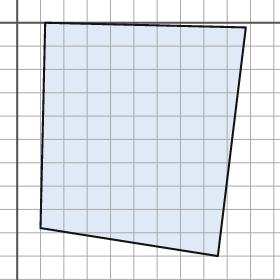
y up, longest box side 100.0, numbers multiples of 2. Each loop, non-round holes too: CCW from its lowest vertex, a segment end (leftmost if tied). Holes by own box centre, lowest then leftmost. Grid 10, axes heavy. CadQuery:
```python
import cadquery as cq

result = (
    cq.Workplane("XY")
    .moveTo(86.0, -100.0)
    .lineTo(98.0, -2.0)
    .lineTo(12.0, 0.0)
    .lineTo(10.0, -88.0)
    .close()
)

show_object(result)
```